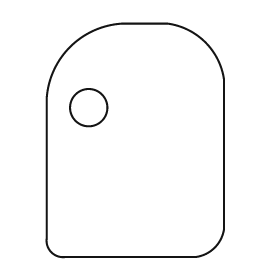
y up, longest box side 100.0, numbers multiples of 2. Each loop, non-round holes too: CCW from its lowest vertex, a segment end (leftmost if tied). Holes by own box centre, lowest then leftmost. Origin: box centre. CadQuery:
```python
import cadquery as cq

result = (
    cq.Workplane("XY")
    .moveTo(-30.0, -50.0)
    .lineTo(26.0, -50.0)
    .threePointArc((34.0, -46.0), (38.0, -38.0))
    .lineTo(38.0, 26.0)
    .threePointArc((30.0, 42.0), (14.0, 50.0))
    .lineTo(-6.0, 50.0)
    .threePointArc((-28.0, 40.0), (-38.0, 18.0))
    .lineTo(-38.0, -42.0)
    .threePointArc((-36.0, -48.0), (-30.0, -50.0))
    .close()
    .moveTo(-20.0, 14.0)
    .circle(8.0)
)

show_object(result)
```